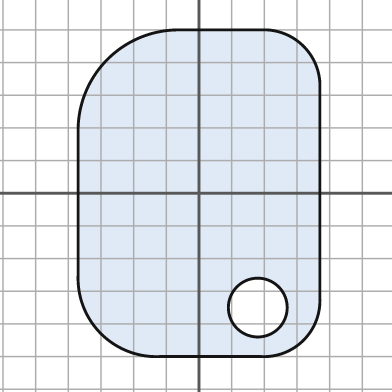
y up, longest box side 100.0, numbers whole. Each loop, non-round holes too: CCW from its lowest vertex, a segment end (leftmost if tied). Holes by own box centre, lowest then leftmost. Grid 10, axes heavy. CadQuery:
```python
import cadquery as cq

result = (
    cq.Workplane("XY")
    .moveTo(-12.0, -50.0)
    .lineTo(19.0, -50.0)
    .threePointArc((32.0, -45.0), (37.0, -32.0))
    .lineTo(37.0, 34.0)
    .threePointArc((32.0, 45.0), (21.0, 50.0))
    .lineTo(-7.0, 50.0)
    .threePointArc((-28.0, 41.0), (-37.0, 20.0))
    .lineTo(-37.0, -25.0)
    .threePointArc((-30.0, -43.0), (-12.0, -50.0))
    .close()
    .moveTo(18.0, -35.0)
    .circle(9.0)
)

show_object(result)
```